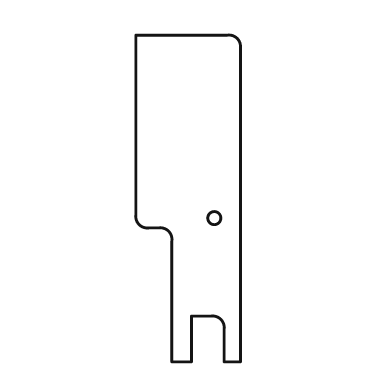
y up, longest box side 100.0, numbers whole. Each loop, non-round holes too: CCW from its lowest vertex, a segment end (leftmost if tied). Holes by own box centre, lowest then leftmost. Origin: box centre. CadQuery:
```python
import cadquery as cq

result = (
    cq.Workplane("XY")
    .moveTo(-5.0, -50.0)
    .lineTo(1.0, -50.0)
    .lineTo(1.0, -36.0)
    .lineTo(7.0, -36.0)
    .threePointArc((10.0, -37.0), (11.0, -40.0))
    .lineTo(11.0, -50.0)
    .lineTo(16.0, -50.0)
    .lineTo(16.0, 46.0)
    .threePointArc((15.0, 49.0), (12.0, 50.0))
    .lineTo(-16.0, 50.0)
    .lineTo(-16.0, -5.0)
    .threePointArc((-15.0, -8.0), (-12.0, -9.0))
    .lineTo(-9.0, -9.0)
    .threePointArc((-6.0, -10.0), (-5.0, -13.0))
    .close()
    .moveTo(8.0, -6.0)
    .circle(2.0)
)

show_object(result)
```